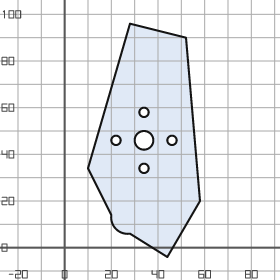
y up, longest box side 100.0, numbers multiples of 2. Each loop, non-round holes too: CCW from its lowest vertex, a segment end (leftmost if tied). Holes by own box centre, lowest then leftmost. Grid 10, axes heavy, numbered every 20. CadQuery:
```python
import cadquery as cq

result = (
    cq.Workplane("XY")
    .moveTo(44.0, -4.0)
    .lineTo(58.0, 20.0)
    .lineTo(52.0, 90.0)
    .lineTo(28.0, 96.0)
    .lineTo(10.0, 34.0)
    .lineTo(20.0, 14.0)
    .threePointArc((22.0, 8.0), (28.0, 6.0))
    .close()
    .moveTo(34.0, 34.0)
    .circle(2.0)
    .moveTo(22.0, 46.0)
    .circle(2.0)
    .moveTo(34.0, 46.0)
    .circle(4.0)
    .moveTo(46.0, 46.0)
    .circle(2.0)
    .moveTo(34.0, 58.0)
    .circle(2.0)
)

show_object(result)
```